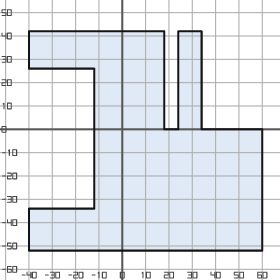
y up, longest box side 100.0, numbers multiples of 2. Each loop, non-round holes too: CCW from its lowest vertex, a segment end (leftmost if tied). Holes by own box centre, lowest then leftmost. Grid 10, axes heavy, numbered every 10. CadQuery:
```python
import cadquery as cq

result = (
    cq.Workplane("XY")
    .moveTo(-40.0, -52.0)
    .lineTo(60.0, -52.0)
    .lineTo(60.0, 0.0)
    .lineTo(34.0, 0.0)
    .lineTo(34.0, 42.0)
    .lineTo(24.0, 42.0)
    .lineTo(24.0, 0.0)
    .lineTo(18.0, 0.0)
    .lineTo(18.0, 42.0)
    .lineTo(-40.0, 42.0)
    .lineTo(-40.0, 26.0)
    .lineTo(-12.0, 26.0)
    .lineTo(-12.0, -34.0)
    .lineTo(-40.0, -34.0)
    .close()
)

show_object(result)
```